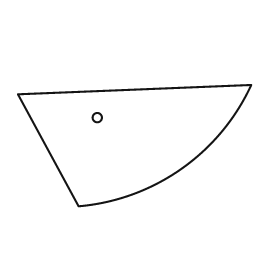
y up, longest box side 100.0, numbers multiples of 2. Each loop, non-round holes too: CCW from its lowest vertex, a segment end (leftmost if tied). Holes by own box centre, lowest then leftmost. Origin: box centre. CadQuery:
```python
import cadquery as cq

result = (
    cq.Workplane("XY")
    .moveTo(-24.0, -26.0)
    .threePointArc((20.0, -10.0), (50.0, 26.0))
    .lineTo(-50.0, 22.0)
    .close()
    .moveTo(-16.0, 12.0)
    .circle(2.0)
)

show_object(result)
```